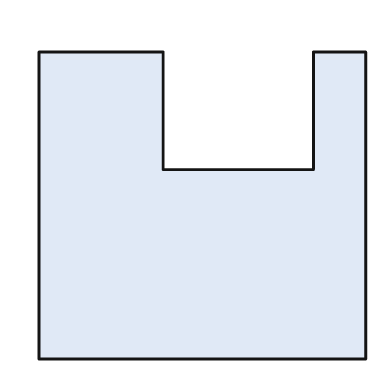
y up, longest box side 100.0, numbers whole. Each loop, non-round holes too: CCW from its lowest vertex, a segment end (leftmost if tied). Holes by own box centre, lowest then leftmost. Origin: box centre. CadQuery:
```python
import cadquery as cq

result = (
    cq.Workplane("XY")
    .moveTo(-50.0, -47.0)
    .lineTo(50.0, -47.0)
    .lineTo(50.0, 47.0)
    .lineTo(34.0, 47.0)
    .lineTo(34.0, 11.0)
    .lineTo(-12.0, 11.0)
    .lineTo(-12.0, 47.0)
    .lineTo(-50.0, 47.0)
    .close()
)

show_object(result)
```